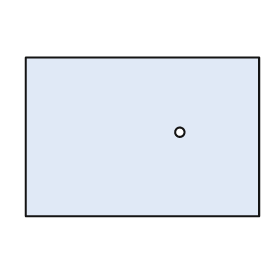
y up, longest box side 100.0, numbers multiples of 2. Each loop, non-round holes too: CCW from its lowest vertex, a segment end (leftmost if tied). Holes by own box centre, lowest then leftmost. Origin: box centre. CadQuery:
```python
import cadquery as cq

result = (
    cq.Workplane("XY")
    .moveTo(-50.0, -34.0)
    .lineTo(50.0, -34.0)
    .lineTo(50.0, 34.0)
    .lineTo(-50.0, 34.0)
    .close()
    .moveTo(16.0, 2.0)
    .circle(2.0)
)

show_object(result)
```